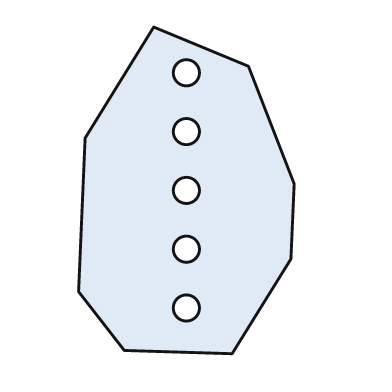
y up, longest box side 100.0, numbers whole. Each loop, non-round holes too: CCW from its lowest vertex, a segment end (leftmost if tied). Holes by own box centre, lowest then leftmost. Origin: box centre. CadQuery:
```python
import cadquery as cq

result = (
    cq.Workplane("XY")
    .moveTo(14.0, -50.0)
    .lineTo(32.0, -21.0)
    .lineTo(33.0, 2.0)
    .lineTo(19.0, 38.0)
    .lineTo(-10.0, 50.0)
    .lineTo(-31.0, 16.0)
    .lineTo(-33.0, -31.0)
    .lineTo(-19.0, -49.0)
    .close()
    .moveTo(0.0, -36.0)
    .circle(4.0)
    .moveTo(0.0, -18.0)
    .circle(4.0)
    .moveTo(0.0, 0.0)
    .circle(4.0)
    .moveTo(0.0, 18.0)
    .circle(4.0)
    .moveTo(0.0, 36.0)
    .circle(4.0)
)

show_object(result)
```